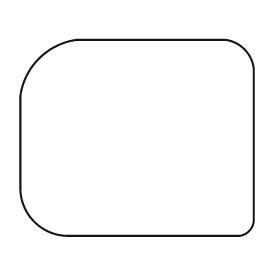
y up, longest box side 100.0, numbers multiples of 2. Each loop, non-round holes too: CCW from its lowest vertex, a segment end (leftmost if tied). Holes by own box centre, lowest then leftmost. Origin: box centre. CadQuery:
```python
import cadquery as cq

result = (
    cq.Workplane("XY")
    .moveTo(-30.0, -42.0)
    .lineTo(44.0, -42.0)
    .threePointArc((48.0, -40.0), (50.0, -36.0))
    .lineTo(50.0, 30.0)
    .threePointArc((46.0, 38.0), (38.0, 42.0))
    .lineTo(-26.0, 42.0)
    .threePointArc((-42.0, 34.0), (-50.0, 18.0))
    .lineTo(-50.0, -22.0)
    .threePointArc((-44.0, -36.0), (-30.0, -42.0))
    .close()
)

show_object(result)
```